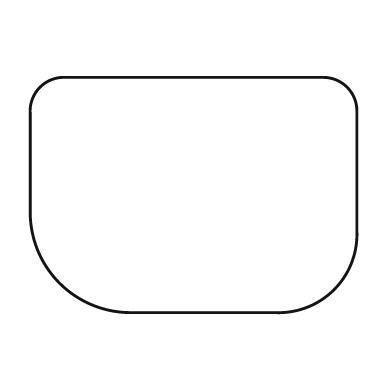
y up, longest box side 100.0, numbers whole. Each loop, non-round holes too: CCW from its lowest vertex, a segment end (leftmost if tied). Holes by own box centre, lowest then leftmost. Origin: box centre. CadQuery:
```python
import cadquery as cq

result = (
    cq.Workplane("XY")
    .moveTo(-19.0, -36.0)
    .lineTo(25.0, -36.0)
    .threePointArc((43.0, -29.0), (50.0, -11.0))
    .lineTo(50.0, 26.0)
    .threePointArc((47.0, 33.0), (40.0, 36.0))
    .lineTo(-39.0, 36.0)
    .threePointArc((-47.0, 33.0), (-50.0, 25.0))
    .lineTo(-50.0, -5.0)
    .threePointArc((-41.0, -27.0), (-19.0, -36.0))
    .close()
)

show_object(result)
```